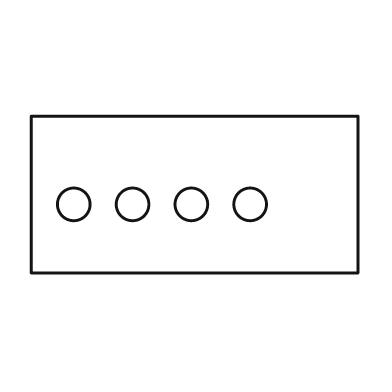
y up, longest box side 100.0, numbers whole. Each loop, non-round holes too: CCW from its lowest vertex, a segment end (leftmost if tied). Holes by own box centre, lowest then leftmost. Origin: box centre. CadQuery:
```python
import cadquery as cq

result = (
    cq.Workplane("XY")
    .moveTo(-50.0, -24.0)
    .lineTo(50.0, -24.0)
    .lineTo(50.0, 24.0)
    .lineTo(-50.0, 24.0)
    .close()
    .moveTo(-37.0, -3.0)
    .circle(5.0)
    .moveTo(-19.0, -3.0)
    .circle(5.0)
    .moveTo(-1.0, -3.0)
    .circle(5.0)
    .moveTo(17.0, -3.0)
    .circle(5.0)
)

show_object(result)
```